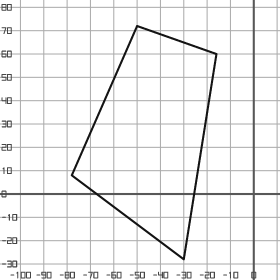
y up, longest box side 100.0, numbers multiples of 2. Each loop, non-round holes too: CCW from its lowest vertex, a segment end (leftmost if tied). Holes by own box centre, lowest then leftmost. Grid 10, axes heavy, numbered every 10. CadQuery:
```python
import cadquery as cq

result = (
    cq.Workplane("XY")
    .moveTo(-30.0, -28.0)
    .lineTo(-16.0, 60.0)
    .lineTo(-50.0, 72.0)
    .lineTo(-78.0, 8.0)
    .close()
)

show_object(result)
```